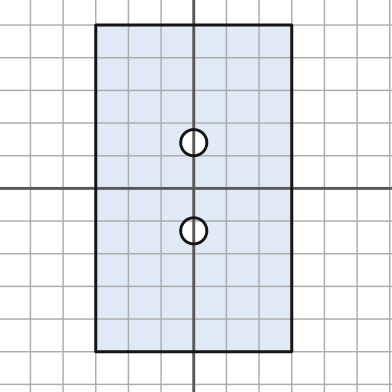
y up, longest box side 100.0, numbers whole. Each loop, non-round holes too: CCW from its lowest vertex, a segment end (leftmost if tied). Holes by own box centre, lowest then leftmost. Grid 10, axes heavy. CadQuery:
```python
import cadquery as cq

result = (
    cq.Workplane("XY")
    .moveTo(-30.0, -50.0)
    .lineTo(30.0, -50.0)
    .lineTo(30.0, 50.0)
    .lineTo(-30.0, 50.0)
    .close()
    .moveTo(0.0, -13.0)
    .circle(4.0)
    .moveTo(0.0, 14.0)
    .circle(4.0)
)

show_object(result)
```